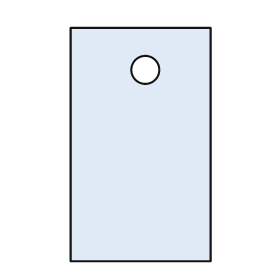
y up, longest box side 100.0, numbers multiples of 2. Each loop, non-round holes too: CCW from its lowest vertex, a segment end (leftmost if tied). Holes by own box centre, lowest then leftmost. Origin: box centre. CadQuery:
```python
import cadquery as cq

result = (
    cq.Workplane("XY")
    .moveTo(-30.0, -50.0)
    .lineTo(30.0, -50.0)
    .lineTo(30.0, 50.0)
    .lineTo(-30.0, 50.0)
    .close()
    .moveTo(2.0, 32.0)
    .circle(6.0)
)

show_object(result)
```